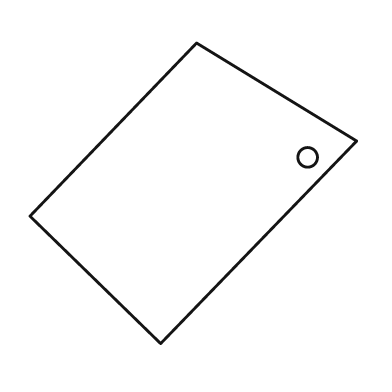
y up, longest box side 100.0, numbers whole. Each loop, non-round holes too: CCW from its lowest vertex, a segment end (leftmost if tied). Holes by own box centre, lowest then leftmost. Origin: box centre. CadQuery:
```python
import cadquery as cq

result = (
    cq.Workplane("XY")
    .moveTo(-10.0, -46.0)
    .lineTo(50.0, 16.0)
    .lineTo(1.0, 46.0)
    .lineTo(-50.0, -7.0)
    .close()
    .moveTo(35.0, 11.0)
    .circle(3.0)
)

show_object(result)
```